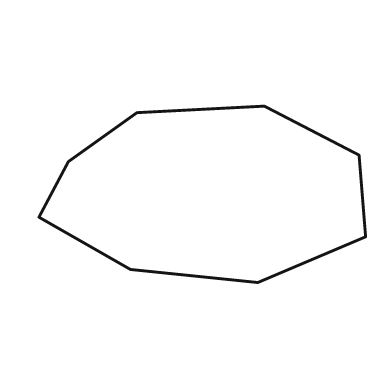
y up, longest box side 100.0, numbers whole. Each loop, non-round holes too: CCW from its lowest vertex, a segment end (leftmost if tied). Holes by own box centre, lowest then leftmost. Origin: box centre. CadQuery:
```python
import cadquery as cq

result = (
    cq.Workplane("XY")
    .moveTo(17.0, -27.0)
    .lineTo(50.0, -13.0)
    .lineTo(48.0, 12.0)
    .lineTo(19.0, 27.0)
    .lineTo(-20.0, 25.0)
    .lineTo(-41.0, 10.0)
    .lineTo(-50.0, -7.0)
    .lineTo(-22.0, -23.0)
    .close()
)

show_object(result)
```